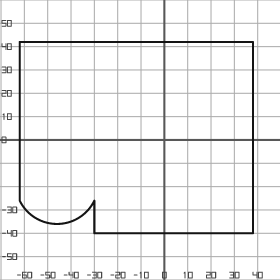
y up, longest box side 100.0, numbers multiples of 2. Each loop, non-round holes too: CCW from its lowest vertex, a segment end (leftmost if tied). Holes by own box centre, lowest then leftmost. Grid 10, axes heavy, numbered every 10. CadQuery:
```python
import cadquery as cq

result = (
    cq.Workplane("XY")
    .moveTo(-30.0, -40.0)
    .lineTo(38.0, -40.0)
    .lineTo(38.0, 42.0)
    .lineTo(-62.0, 42.0)
    .lineTo(-62.0, -26.0)
    .threePointArc((-46.0, -36.0), (-30.0, -26.0))
    .close()
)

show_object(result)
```